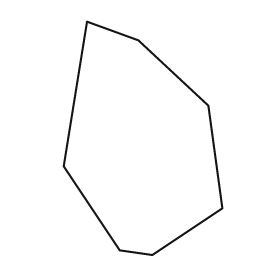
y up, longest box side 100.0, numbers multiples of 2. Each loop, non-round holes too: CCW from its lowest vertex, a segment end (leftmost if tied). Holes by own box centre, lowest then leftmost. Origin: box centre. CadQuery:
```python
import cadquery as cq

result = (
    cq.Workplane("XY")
    .moveTo(4.0, -50.0)
    .lineTo(34.0, -30.0)
    .lineTo(28.0, 14.0)
    .lineTo(-2.0, 42.0)
    .lineTo(-24.0, 50.0)
    .lineTo(-34.0, -12.0)
    .lineTo(-10.0, -48.0)
    .close()
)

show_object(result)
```